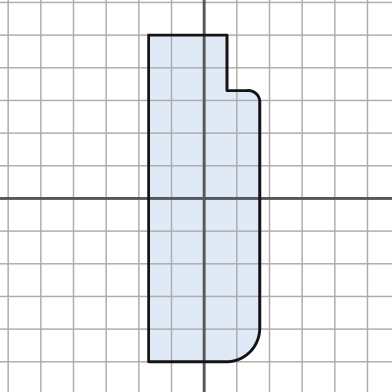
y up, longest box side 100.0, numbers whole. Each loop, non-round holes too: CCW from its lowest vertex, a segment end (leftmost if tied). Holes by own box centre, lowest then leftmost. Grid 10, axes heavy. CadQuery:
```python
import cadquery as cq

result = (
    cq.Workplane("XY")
    .moveTo(-17.0, -50.0)
    .lineTo(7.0, -50.0)
    .threePointArc((14.0, -47.0), (17.0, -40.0))
    .lineTo(17.0, 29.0)
    .threePointArc((16.0, 32.0), (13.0, 33.0))
    .lineTo(7.0, 33.0)
    .lineTo(7.0, 50.0)
    .lineTo(-17.0, 50.0)
    .close()
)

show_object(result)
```